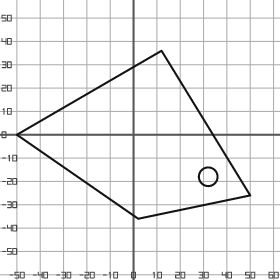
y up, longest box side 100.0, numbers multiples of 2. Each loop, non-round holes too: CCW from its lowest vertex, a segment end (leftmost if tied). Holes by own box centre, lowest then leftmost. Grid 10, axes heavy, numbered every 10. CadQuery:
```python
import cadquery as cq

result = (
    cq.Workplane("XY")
    .moveTo(2.0, -36.0)
    .lineTo(50.0, -26.0)
    .lineTo(12.0, 36.0)
    .lineTo(-50.0, 0.0)
    .close()
    .moveTo(32.0, -18.0)
    .circle(4.0)
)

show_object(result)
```